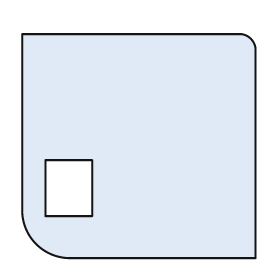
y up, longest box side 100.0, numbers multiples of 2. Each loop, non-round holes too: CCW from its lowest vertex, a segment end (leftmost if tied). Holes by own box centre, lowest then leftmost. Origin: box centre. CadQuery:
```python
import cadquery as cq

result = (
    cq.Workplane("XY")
    .moveTo(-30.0, -48.0)
    .lineTo(50.0, -48.0)
    .lineTo(50.0, 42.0)
    .threePointArc((48.0, 46.0), (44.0, 48.0))
    .lineTo(-50.0, 48.0)
    .lineTo(-50.0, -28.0)
    .threePointArc((-44.0, -42.0), (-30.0, -48.0))
    .close()
    .moveTo(-40.0, -30.0)
    .lineTo(-20.0, -30.0)
    .lineTo(-20.0, -6.0)
    .lineTo(-40.0, -6.0)
    .close()
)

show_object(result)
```